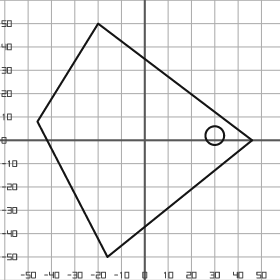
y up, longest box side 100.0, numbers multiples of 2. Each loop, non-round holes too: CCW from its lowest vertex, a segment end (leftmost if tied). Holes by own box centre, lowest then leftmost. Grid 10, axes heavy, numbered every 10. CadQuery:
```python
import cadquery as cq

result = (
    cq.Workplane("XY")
    .moveTo(-16.0, -50.0)
    .lineTo(46.0, 0.0)
    .lineTo(-20.0, 50.0)
    .lineTo(-46.0, 8.0)
    .close()
    .moveTo(30.0, 2.0)
    .circle(4.0)
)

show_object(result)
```